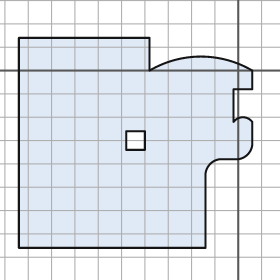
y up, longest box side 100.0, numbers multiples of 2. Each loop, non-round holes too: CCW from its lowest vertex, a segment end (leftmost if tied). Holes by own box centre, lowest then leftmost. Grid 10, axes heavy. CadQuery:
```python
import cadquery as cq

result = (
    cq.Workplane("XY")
    .moveTo(-94.0, -76.0)
    .lineTo(-14.0, -76.0)
    .lineTo(-14.0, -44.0)
    .threePointArc((-12.0, -40.0), (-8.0, -38.0))
    .lineTo(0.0, -38.0)
    .threePointArc((4.0, -36.0), (6.0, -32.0))
    .lineTo(6.0, -22.0)
    .threePointArc((2.0, -20.0), (-2.0, -22.0))
    .lineTo(-2.0, -8.0)
    .lineTo(6.0, -8.0)
    .lineTo(6.0, 0.0)
    .threePointArc((-16.0, 6.0), (-38.0, 0.0))
    .lineTo(-38.0, 14.0)
    .lineTo(-94.0, 14.0)
    .close()
    .moveTo(-48.0, -34.0)
    .lineTo(-40.0, -34.0)
    .lineTo(-40.0, -26.0)
    .lineTo(-48.0, -26.0)
    .close()
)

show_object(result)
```